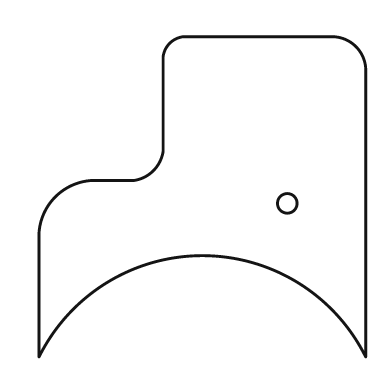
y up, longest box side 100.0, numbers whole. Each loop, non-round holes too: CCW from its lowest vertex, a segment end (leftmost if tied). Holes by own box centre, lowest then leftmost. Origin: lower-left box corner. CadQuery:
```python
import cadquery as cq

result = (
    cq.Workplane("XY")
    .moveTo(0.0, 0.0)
    .threePointArc((50.0, 31.0), (100.0, 0.0))
    .lineTo(100.0, 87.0)
    .threePointArc((97.0, 95.0), (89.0, 98.0))
    .lineTo(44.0, 98.0)
    .threePointArc((40.0, 96.0), (38.0, 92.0))
    .lineTo(38.0, 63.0)
    .threePointArc((35.0, 57.0), (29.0, 54.0))
    .lineTo(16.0, 54.0)
    .threePointArc((5.0, 49.0), (0.0, 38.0))
    .close()
    .moveTo(76.0, 47.0)
    .circle(3.0)
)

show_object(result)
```